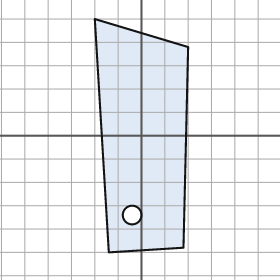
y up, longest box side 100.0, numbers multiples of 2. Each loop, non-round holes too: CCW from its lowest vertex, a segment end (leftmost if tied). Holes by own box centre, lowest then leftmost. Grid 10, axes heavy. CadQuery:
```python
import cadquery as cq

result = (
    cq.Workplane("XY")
    .moveTo(-14.0, -50.0)
    .lineTo(18.0, -48.0)
    .lineTo(20.0, 38.0)
    .lineTo(-20.0, 50.0)
    .close()
    .moveTo(-4.0, -34.0)
    .circle(4.0)
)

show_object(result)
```